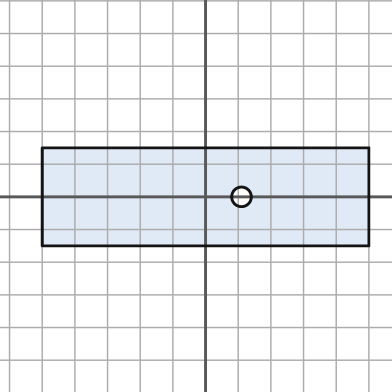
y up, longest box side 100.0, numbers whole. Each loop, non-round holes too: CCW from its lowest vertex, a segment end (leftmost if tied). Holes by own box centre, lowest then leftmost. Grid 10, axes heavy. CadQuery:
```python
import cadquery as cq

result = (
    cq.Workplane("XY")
    .moveTo(-50.0, -15.0)
    .lineTo(50.0, -15.0)
    .lineTo(50.0, 15.0)
    .lineTo(-50.0, 15.0)
    .close()
    .moveTo(11.0, 0.0)
    .circle(3.0)
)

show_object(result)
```